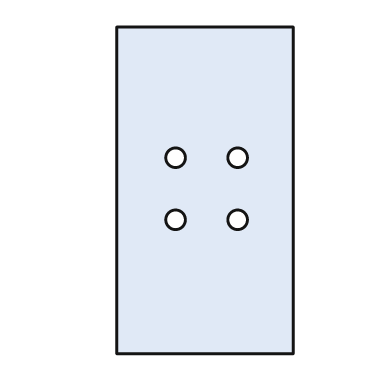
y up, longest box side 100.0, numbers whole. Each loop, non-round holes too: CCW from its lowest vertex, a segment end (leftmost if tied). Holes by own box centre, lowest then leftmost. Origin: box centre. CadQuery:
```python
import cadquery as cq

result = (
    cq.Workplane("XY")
    .moveTo(-27.0, -50.0)
    .lineTo(27.0, -50.0)
    .lineTo(27.0, 50.0)
    .lineTo(-27.0, 50.0)
    .close()
    .moveTo(-9.0, -9.0)
    .circle(3.0)
    .moveTo(10.0, -9.0)
    .circle(3.0)
    .moveTo(-9.0, 10.0)
    .circle(3.0)
    .moveTo(10.0, 10.0)
    .circle(3.0)
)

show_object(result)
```